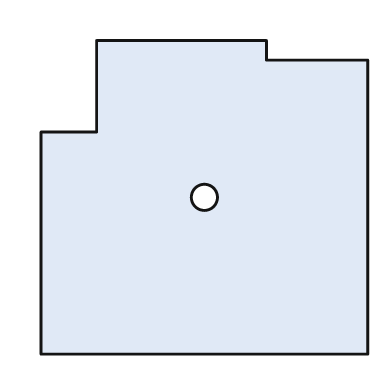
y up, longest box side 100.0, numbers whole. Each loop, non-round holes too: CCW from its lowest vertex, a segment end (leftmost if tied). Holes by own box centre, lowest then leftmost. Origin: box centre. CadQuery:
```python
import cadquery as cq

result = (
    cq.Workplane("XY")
    .moveTo(-50.0, -48.0)
    .lineTo(50.0, -48.0)
    .lineTo(50.0, 42.0)
    .lineTo(19.0, 42.0)
    .lineTo(19.0, 48.0)
    .lineTo(-33.0, 48.0)
    .lineTo(-33.0, 20.0)
    .lineTo(-50.0, 20.0)
    .close()
    .moveTo(0.0, 0.0)
    .circle(4.0)
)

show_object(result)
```